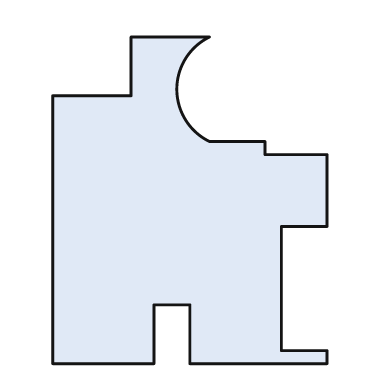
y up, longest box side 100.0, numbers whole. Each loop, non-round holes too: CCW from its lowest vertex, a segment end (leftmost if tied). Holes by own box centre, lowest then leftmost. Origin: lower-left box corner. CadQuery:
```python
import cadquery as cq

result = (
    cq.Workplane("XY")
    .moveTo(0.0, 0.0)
    .lineTo(31.0, 0.0)
    .lineTo(31.0, 18.0)
    .lineTo(42.0, 18.0)
    .lineTo(42.0, 0.0)
    .lineTo(84.0, 0.0)
    .lineTo(84.0, 4.0)
    .lineTo(70.0, 4.0)
    .lineTo(70.0, 42.0)
    .lineTo(84.0, 42.0)
    .lineTo(84.0, 64.0)
    .lineTo(65.0, 64.0)
    .lineTo(65.0, 68.0)
    .lineTo(48.0, 68.0)
    .threePointArc((38.0, 84.0), (48.0, 100.0))
    .lineTo(24.0, 100.0)
    .lineTo(24.0, 82.0)
    .lineTo(0.0, 82.0)
    .close()
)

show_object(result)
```